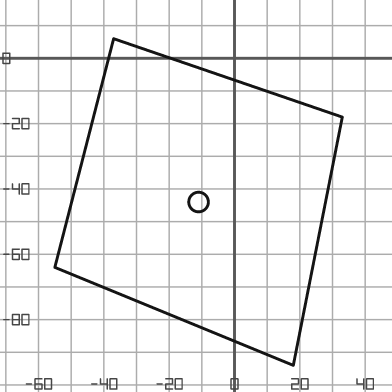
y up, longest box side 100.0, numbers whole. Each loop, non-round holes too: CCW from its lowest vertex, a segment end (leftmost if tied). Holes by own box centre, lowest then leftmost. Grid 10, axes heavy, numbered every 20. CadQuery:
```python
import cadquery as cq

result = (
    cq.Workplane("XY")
    .moveTo(18.0, -94.0)
    .lineTo(33.0, -18.0)
    .lineTo(-37.0, 6.0)
    .lineTo(-55.0, -64.0)
    .close()
    .moveTo(-11.0, -44.0)
    .circle(3.0)
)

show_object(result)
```